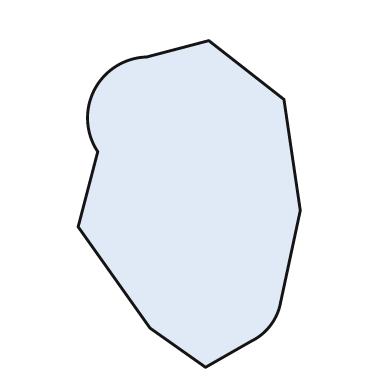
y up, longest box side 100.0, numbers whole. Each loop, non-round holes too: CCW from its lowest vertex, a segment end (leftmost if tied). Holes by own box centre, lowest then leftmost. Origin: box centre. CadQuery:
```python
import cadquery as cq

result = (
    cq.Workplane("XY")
    .moveTo(5.0, -50.0)
    .lineTo(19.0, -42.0)
    .threePointArc((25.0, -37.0), (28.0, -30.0))
    .lineTo(34.0, -2.0)
    .lineTo(29.0, 32.0)
    .lineTo(6.0, 50.0)
    .lineTo(-13.0, 45.0)
    .threePointArc((-29.0, 35.0), (-28.0, 16.0))
    .lineTo(-34.0, -7.0)
    .lineTo(-12.0, -38.0)
    .close()
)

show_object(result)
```